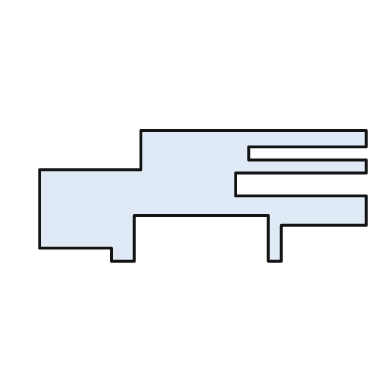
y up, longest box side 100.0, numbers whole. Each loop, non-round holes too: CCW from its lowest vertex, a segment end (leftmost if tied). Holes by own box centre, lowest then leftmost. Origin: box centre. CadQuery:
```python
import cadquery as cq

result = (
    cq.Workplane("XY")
    .moveTo(-28.0, -20.0)
    .lineTo(-21.0, -20.0)
    .lineTo(-21.0, -6.0)
    .lineTo(20.0, -6.0)
    .lineTo(20.0, -20.0)
    .lineTo(24.0, -20.0)
    .lineTo(24.0, -9.0)
    .lineTo(50.0, -9.0)
    .lineTo(50.0, 0.0)
    .lineTo(10.0, 0.0)
    .lineTo(10.0, 7.0)
    .lineTo(50.0, 7.0)
    .lineTo(50.0, 11.0)
    .lineTo(14.0, 11.0)
    .lineTo(14.0, 15.0)
    .lineTo(50.0, 15.0)
    .lineTo(50.0, 20.0)
    .lineTo(-19.0, 20.0)
    .lineTo(-19.0, 8.0)
    .lineTo(-50.0, 8.0)
    .lineTo(-50.0, -16.0)
    .lineTo(-28.0, -16.0)
    .close()
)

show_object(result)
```